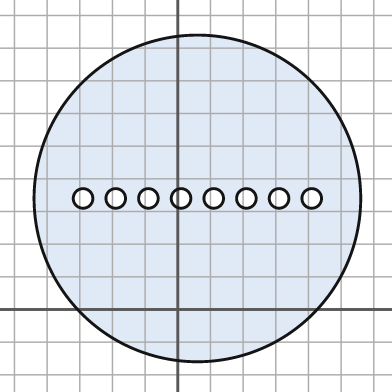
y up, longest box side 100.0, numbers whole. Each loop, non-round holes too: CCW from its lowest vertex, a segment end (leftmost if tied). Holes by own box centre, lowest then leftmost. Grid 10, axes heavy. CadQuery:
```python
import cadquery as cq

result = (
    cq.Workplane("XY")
    .moveTo(6.0, 34.0)
    .circle(50.0)
    .moveTo(-29.0, 34.0)
    .circle(3.0)
    .moveTo(-19.0, 34.0)
    .circle(3.0)
    .moveTo(-9.0, 34.0)
    .circle(3.0)
    .moveTo(1.0, 34.0)
    .circle(3.0)
    .moveTo(11.0, 34.0)
    .circle(3.0)
    .moveTo(21.0, 34.0)
    .circle(3.0)
    .moveTo(31.0, 34.0)
    .circle(3.0)
    .moveTo(41.0, 34.0)
    .circle(3.0)
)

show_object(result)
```